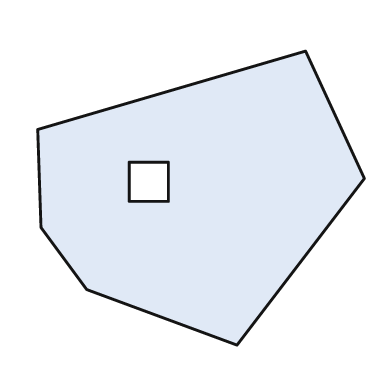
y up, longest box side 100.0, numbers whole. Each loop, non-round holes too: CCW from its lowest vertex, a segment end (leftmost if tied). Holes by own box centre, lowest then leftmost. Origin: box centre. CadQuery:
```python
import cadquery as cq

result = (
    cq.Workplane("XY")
    .moveTo(11.0, -45.0)
    .lineTo(50.0, 6.0)
    .lineTo(32.0, 45.0)
    .lineTo(-50.0, 21.0)
    .lineTo(-49.0, -9.0)
    .lineTo(-35.0, -28.0)
    .close()
    .moveTo(-22.0, -1.0)
    .lineTo(-10.0, -1.0)
    .lineTo(-10.0, 11.0)
    .lineTo(-22.0, 11.0)
    .close()
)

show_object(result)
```